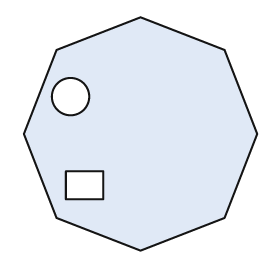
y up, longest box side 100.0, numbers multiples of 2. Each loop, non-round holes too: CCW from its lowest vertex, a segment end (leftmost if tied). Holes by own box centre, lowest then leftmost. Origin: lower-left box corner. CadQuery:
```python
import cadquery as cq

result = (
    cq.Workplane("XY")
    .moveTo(50.0, 0.0)
    .lineTo(86.0, 14.0)
    .lineTo(100.0, 50.0)
    .lineTo(86.0, 86.0)
    .lineTo(50.0, 100.0)
    .lineTo(14.0, 86.0)
    .lineTo(0.0, 50.0)
    .lineTo(14.0, 14.0)
    .close()
    .moveTo(18.0, 22.0)
    .lineTo(34.0, 22.0)
    .lineTo(34.0, 34.0)
    .lineTo(18.0, 34.0)
    .close()
    .moveTo(20.0, 66.0)
    .circle(8.0)
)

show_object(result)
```